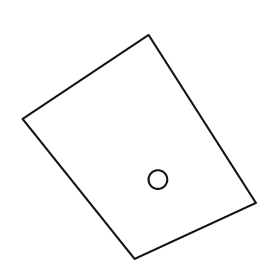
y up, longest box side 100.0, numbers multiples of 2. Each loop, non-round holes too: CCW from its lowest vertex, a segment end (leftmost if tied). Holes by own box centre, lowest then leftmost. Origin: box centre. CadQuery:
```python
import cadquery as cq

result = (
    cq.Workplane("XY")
    .moveTo(-2.0, -48.0)
    .lineTo(50.0, -24.0)
    .lineTo(4.0, 48.0)
    .lineTo(-50.0, 12.0)
    .close()
    .moveTo(8.0, -14.0)
    .circle(4.0)
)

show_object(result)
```